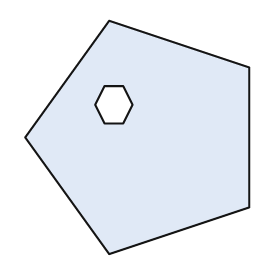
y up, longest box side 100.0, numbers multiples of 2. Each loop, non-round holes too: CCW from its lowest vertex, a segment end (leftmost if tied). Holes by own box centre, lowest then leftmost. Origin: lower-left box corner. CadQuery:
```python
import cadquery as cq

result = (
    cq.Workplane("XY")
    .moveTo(36.0, 0.0)
    .lineTo(96.0, 20.0)
    .lineTo(96.0, 80.0)
    .lineTo(36.0, 100.0)
    .lineTo(0.0, 50.0)
    .close()
    .moveTo(34.0, 56.0)
    .lineTo(42.0, 56.0)
    .lineTo(46.0, 64.0)
    .lineTo(42.0, 72.0)
    .lineTo(34.0, 72.0)
    .lineTo(30.0, 64.0)
    .close()
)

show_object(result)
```